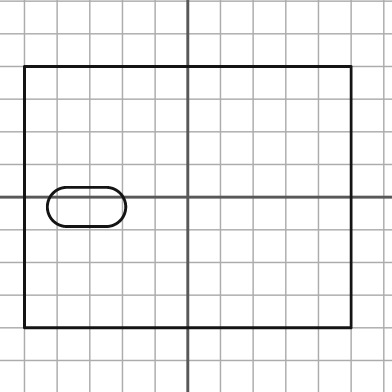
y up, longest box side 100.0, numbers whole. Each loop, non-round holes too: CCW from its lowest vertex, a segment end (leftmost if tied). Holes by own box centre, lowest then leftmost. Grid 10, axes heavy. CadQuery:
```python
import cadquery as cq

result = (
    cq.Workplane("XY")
    .moveTo(-50.0, -40.0)
    .lineTo(50.0, -40.0)
    .lineTo(50.0, 40.0)
    .lineTo(-50.0, 40.0)
    .close()
    .moveTo(-37.0, -9.0)
    .lineTo(-25.0, -9.0)
    .threePointArc((-19.0, -3.0), (-25.0, 3.0))
    .lineTo(-37.0, 3.0)
    .threePointArc((-43.0, -3.0), (-37.0, -9.0))
    .close()
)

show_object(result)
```